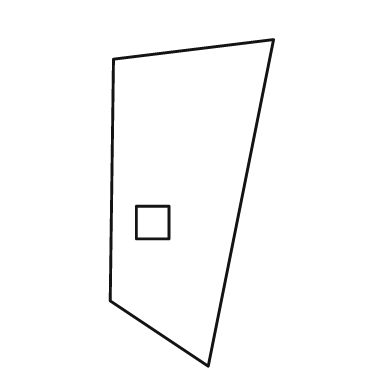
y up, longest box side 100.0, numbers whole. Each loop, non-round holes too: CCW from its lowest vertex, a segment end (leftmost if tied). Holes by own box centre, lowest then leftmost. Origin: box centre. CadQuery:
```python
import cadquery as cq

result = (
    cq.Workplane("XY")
    .moveTo(5.0, -50.0)
    .lineTo(25.0, 50.0)
    .lineTo(-24.0, 44.0)
    .lineTo(-25.0, -30.0)
    .close()
    .moveTo(-17.0, -11.0)
    .lineTo(-7.0, -11.0)
    .lineTo(-7.0, -1.0)
    .lineTo(-17.0, -1.0)
    .close()
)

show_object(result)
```